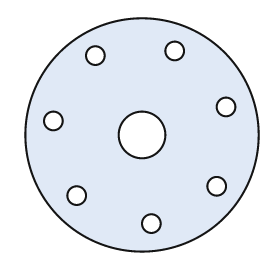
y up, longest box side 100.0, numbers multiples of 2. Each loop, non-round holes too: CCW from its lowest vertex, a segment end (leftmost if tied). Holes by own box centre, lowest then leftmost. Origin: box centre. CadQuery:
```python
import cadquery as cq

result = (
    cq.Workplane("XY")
    .moveTo(0.0, 0.0)
    .circle(50.0)
    .moveTo(4.0, -38.0)
    .circle(4.0)
    .moveTo(-28.0, -26.0)
    .circle(4.0)
    .moveTo(32.0, -22.0)
    .circle(4.0)
    .moveTo(0.0, 0.0)
    .circle(10.0)
    .moveTo(-38.0, 6.0)
    .circle(4.0)
    .moveTo(36.0, 12.0)
    .circle(4.0)
    .moveTo(-20.0, 34.0)
    .circle(4.0)
    .moveTo(14.0, 36.0)
    .circle(4.0)
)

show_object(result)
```